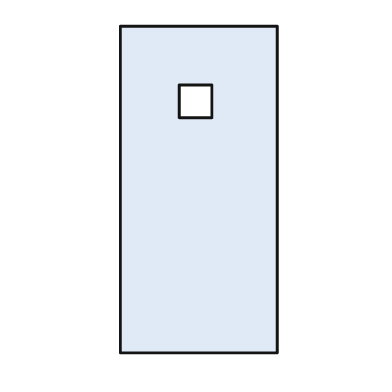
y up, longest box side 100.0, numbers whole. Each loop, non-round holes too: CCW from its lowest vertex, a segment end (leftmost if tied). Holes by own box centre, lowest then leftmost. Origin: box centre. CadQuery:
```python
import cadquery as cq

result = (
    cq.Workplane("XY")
    .moveTo(-24.0, -50.0)
    .lineTo(24.0, -50.0)
    .lineTo(24.0, 50.0)
    .lineTo(-24.0, 50.0)
    .close()
    .moveTo(-6.0, 22.0)
    .lineTo(4.0, 22.0)
    .lineTo(4.0, 32.0)
    .lineTo(-6.0, 32.0)
    .close()
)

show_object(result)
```